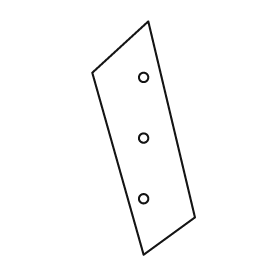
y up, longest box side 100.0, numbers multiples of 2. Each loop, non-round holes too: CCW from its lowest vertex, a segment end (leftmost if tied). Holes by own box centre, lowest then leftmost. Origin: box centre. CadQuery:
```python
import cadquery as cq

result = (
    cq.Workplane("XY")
    .moveTo(0.0, -50.0)
    .lineTo(22.0, -34.0)
    .lineTo(2.0, 50.0)
    .lineTo(-22.0, 28.0)
    .close()
    .moveTo(0.0, -26.0)
    .circle(2.0)
    .moveTo(0.0, 0.0)
    .circle(2.0)
    .moveTo(0.0, 26.0)
    .circle(2.0)
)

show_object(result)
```